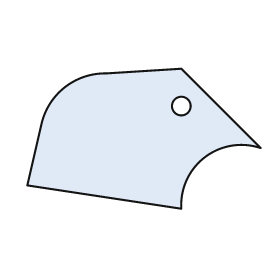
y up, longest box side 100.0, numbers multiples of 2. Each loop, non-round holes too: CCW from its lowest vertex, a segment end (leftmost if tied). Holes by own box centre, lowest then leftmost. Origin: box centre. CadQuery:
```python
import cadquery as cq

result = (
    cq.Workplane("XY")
    .moveTo(16.0, -30.0)
    .threePointArc((26.0, -8.0), (50.0, -4.0))
    .lineTo(16.0, 30.0)
    .lineTo(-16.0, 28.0)
    .threePointArc((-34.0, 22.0), (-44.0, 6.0))
    .lineTo(-50.0, -20.0)
    .close()
    .moveTo(16.0, 14.0)
    .circle(4.0)
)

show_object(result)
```